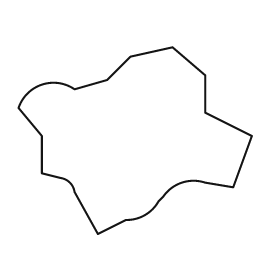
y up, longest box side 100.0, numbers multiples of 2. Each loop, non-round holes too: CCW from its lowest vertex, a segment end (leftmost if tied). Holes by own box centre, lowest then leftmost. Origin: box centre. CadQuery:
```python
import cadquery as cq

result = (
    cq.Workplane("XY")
    .moveTo(-16.0, -40.0)
    .lineTo(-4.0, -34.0)
    .threePointArc((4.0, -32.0), (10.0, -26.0))
    .lineTo(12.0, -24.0)
    .threePointArc((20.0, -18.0), (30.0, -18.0))
    .lineTo(42.0, -20.0)
    .lineTo(50.0, 2.0)
    .lineTo(30.0, 12.0)
    .lineTo(30.0, 28.0)
    .lineTo(16.0, 40.0)
    .lineTo(-2.0, 36.0)
    .lineTo(-12.0, 26.0)
    .lineTo(-26.0, 22.0)
    .threePointArc((-40.0, 24.0), (-50.0, 14.0))
    .lineTo(-40.0, 2.0)
    .lineTo(-40.0, -14.0)
    .lineTo(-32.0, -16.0)
    .threePointArc((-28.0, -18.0), (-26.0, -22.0))
    .close()
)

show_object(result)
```